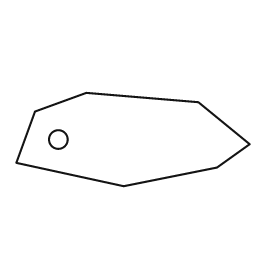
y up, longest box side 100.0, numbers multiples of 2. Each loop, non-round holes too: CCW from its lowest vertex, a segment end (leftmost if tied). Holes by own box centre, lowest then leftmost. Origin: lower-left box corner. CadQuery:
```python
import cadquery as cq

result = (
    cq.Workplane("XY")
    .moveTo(46.0, 0.0)
    .lineTo(86.0, 8.0)
    .lineTo(100.0, 18.0)
    .lineTo(78.0, 36.0)
    .lineTo(30.0, 40.0)
    .lineTo(8.0, 32.0)
    .lineTo(0.0, 10.0)
    .close()
    .moveTo(18.0, 20.0)
    .circle(4.0)
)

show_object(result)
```